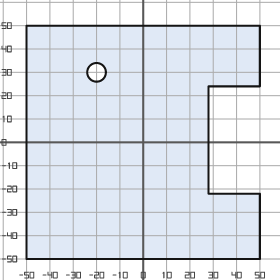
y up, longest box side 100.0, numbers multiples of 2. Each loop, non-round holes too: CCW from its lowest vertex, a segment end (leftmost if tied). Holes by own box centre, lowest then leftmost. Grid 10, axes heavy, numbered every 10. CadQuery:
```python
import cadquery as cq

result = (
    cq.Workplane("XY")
    .moveTo(-50.0, -50.0)
    .lineTo(50.0, -50.0)
    .lineTo(50.0, -22.0)
    .lineTo(28.0, -22.0)
    .lineTo(28.0, 24.0)
    .lineTo(50.0, 24.0)
    .lineTo(50.0, 50.0)
    .lineTo(-50.0, 50.0)
    .close()
    .moveTo(-20.0, 30.0)
    .circle(4.0)
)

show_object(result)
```